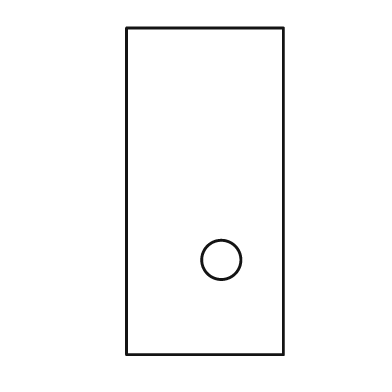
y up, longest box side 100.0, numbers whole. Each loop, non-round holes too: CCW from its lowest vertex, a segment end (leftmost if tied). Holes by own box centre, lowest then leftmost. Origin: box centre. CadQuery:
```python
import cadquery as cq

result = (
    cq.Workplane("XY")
    .moveTo(-24.0, -50.0)
    .lineTo(24.0, -50.0)
    .lineTo(24.0, 50.0)
    .lineTo(-24.0, 50.0)
    .close()
    .moveTo(5.0, -21.0)
    .circle(6.0)
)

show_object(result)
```